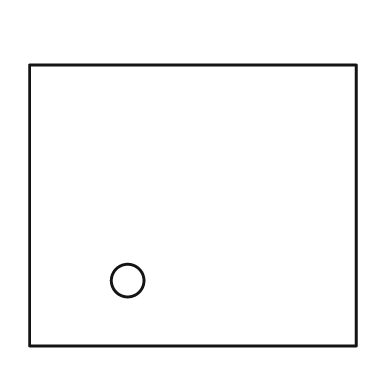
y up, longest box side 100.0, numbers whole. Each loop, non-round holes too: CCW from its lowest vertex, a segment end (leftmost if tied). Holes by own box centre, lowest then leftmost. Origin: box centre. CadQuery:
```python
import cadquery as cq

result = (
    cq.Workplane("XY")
    .moveTo(-50.0, -43.0)
    .lineTo(50.0, -43.0)
    .lineTo(50.0, 43.0)
    .lineTo(-50.0, 43.0)
    .close()
    .moveTo(-20.0, -23.0)
    .circle(5.0)
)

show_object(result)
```